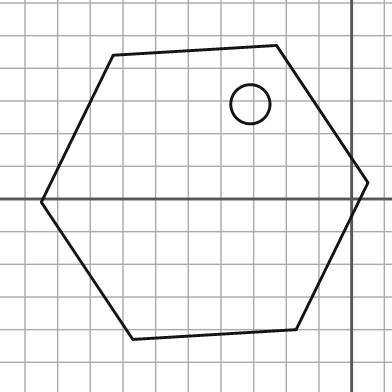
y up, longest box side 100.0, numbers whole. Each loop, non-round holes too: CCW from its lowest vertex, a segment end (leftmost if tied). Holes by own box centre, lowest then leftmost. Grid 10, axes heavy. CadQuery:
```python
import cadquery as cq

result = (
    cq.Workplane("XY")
    .moveTo(-67.0, -43.0)
    .lineTo(-17.0, -40.0)
    .lineTo(5.0, 5.0)
    .lineTo(-23.0, 47.0)
    .lineTo(-73.0, 44.0)
    .lineTo(-95.0, -1.0)
    .close()
    .moveTo(-31.0, 29.0)
    .circle(6.0)
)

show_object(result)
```